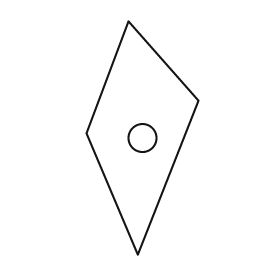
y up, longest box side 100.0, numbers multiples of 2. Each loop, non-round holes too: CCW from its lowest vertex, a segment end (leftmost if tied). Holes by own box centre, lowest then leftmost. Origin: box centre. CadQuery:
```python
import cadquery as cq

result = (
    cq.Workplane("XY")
    .moveTo(-2.0, -50.0)
    .lineTo(24.0, 16.0)
    .lineTo(-6.0, 50.0)
    .lineTo(-24.0, 2.0)
    .close()
    .moveTo(0.0, 0.0)
    .circle(6.0)
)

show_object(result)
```